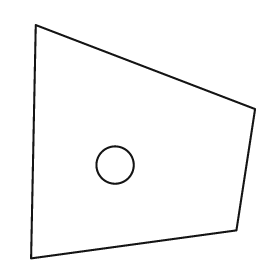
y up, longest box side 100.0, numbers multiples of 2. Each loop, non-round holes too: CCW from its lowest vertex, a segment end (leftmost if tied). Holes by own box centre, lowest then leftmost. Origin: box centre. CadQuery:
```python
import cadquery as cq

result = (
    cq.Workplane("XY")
    .moveTo(-48.0, -50.0)
    .lineTo(40.0, -38.0)
    .lineTo(48.0, 14.0)
    .lineTo(-46.0, 50.0)
    .close()
    .moveTo(-12.0, -10.0)
    .circle(8.0)
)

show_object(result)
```